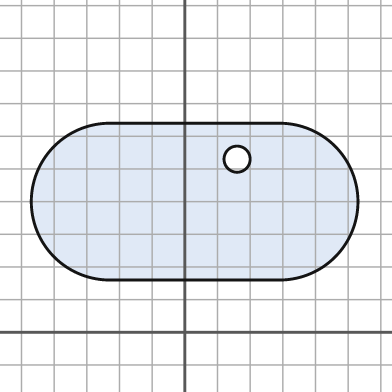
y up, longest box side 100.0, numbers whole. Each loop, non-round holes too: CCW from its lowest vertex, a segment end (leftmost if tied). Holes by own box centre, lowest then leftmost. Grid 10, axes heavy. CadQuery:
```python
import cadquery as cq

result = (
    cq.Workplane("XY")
    .moveTo(-23.0, 16.0)
    .lineTo(29.0, 16.0)
    .threePointArc((53.0, 40.0), (29.0, 64.0))
    .lineTo(-23.0, 64.0)
    .threePointArc((-47.0, 40.0), (-23.0, 16.0))
    .close()
    .moveTo(16.0, 53.0)
    .circle(4.0)
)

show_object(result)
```